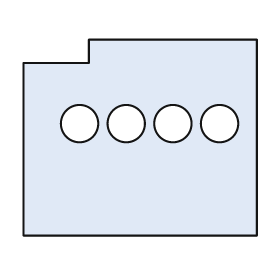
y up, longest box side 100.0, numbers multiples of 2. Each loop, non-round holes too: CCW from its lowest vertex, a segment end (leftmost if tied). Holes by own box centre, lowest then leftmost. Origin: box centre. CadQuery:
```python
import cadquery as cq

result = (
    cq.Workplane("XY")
    .moveTo(-50.0, -42.0)
    .lineTo(50.0, -42.0)
    .lineTo(50.0, 42.0)
    .lineTo(-22.0, 42.0)
    .lineTo(-22.0, 32.0)
    .lineTo(-50.0, 32.0)
    .close()
    .moveTo(-26.0, 6.0)
    .circle(8.0)
    .moveTo(-6.0, 6.0)
    .circle(8.0)
    .moveTo(14.0, 6.0)
    .circle(8.0)
    .moveTo(34.0, 6.0)
    .circle(8.0)
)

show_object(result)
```